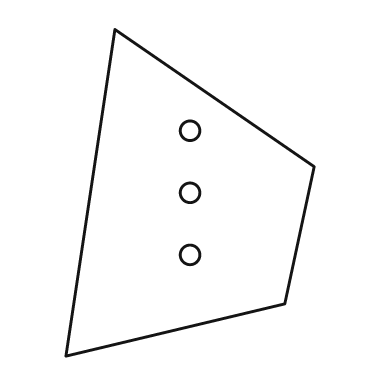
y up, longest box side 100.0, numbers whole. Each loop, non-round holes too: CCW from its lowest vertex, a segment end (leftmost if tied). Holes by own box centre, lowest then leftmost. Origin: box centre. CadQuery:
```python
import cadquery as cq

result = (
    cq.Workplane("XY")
    .moveTo(-38.0, -50.0)
    .lineTo(29.0, -34.0)
    .lineTo(38.0, 8.0)
    .lineTo(-23.0, 50.0)
    .close()
    .moveTo(0.0, -19.0)
    .circle(3.0)
    .moveTo(0.0, 0.0)
    .circle(3.0)
    .moveTo(0.0, 19.0)
    .circle(3.0)
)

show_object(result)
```